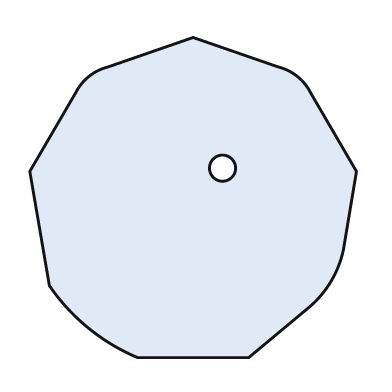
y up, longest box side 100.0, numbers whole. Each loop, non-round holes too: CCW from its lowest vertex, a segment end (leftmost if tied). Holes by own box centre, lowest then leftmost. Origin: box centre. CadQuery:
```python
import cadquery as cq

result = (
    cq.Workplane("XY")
    .moveTo(-17.0, -49.0)
    .lineTo(17.0, -49.0)
    .lineTo(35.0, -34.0)
    .threePointArc((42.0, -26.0), (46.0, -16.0))
    .lineTo(50.0, 8.0)
    .lineTo(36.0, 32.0)
    .threePointArc((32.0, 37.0), (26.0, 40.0))
    .lineTo(0.0, 49.0)
    .lineTo(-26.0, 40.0)
    .threePointArc((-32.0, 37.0), (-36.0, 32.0))
    .lineTo(-50.0, 8.0)
    .lineTo(-44.0, -27.0)
    .threePointArc((-32.0, -40.0), (-17.0, -49.0))
    .close()
    .moveTo(9.0, 9.0)
    .circle(4.0)
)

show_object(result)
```